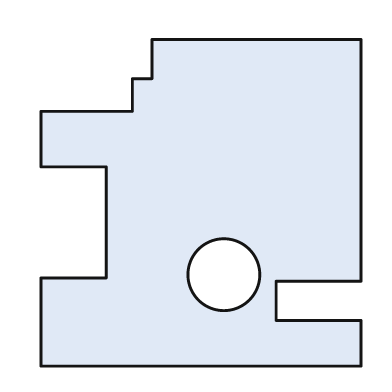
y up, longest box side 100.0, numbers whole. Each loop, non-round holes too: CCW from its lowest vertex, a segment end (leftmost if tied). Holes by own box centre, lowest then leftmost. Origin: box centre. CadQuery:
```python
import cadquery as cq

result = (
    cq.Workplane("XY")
    .moveTo(-49.0, -50.0)
    .lineTo(49.0, -50.0)
    .lineTo(49.0, -36.0)
    .lineTo(23.0, -36.0)
    .lineTo(23.0, -24.0)
    .lineTo(49.0, -24.0)
    .lineTo(49.0, 50.0)
    .lineTo(-15.0, 50.0)
    .lineTo(-15.0, 38.0)
    .lineTo(-21.0, 38.0)
    .lineTo(-21.0, 28.0)
    .lineTo(-49.0, 28.0)
    .lineTo(-49.0, 11.0)
    .lineTo(-29.0, 11.0)
    .lineTo(-29.0, -23.0)
    .lineTo(-49.0, -23.0)
    .close()
    .moveTo(7.0, -22.0)
    .circle(11.0)
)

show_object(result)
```